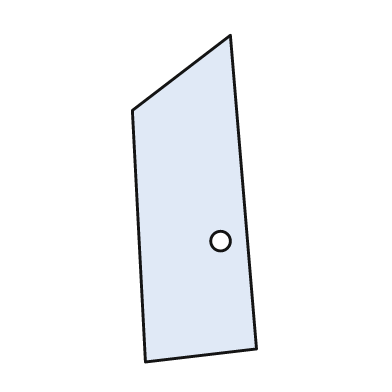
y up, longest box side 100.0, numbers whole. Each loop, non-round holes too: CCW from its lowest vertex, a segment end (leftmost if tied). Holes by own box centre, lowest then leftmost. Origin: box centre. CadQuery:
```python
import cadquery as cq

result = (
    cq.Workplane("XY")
    .moveTo(-15.0, -50.0)
    .lineTo(19.0, -46.0)
    .lineTo(11.0, 50.0)
    .lineTo(-19.0, 27.0)
    .close()
    .moveTo(8.0, -13.0)
    .circle(3.0)
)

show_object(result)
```